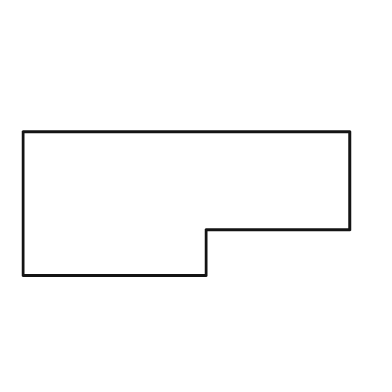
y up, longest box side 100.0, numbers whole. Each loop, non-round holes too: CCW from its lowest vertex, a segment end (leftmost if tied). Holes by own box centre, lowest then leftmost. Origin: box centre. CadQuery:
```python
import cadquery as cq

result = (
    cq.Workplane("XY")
    .moveTo(-50.0, -22.0)
    .lineTo(6.0, -22.0)
    .lineTo(6.0, -8.0)
    .lineTo(50.0, -8.0)
    .lineTo(50.0, 22.0)
    .lineTo(-50.0, 22.0)
    .close()
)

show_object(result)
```